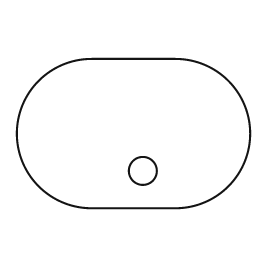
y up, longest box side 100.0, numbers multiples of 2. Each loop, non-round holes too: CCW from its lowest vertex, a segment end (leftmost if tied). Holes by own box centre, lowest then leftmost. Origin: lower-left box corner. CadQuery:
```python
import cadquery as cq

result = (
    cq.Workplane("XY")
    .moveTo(32.0, 0.0)
    .lineTo(68.0, 0.0)
    .threePointArc((100.0, 32.0), (68.0, 64.0))
    .lineTo(32.0, 64.0)
    .threePointArc((0.0, 32.0), (32.0, 0.0))
    .close()
    .moveTo(54.0, 16.0)
    .circle(6.0)
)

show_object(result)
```